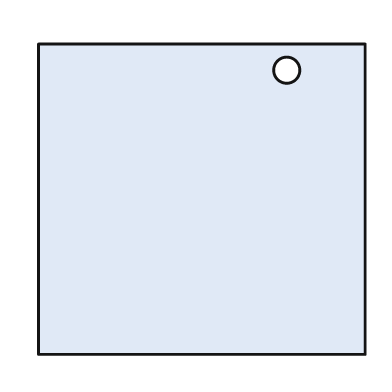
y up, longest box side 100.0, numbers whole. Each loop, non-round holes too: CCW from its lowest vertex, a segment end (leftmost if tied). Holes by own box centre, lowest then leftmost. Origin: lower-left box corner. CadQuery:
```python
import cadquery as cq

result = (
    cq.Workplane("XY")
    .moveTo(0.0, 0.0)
    .lineTo(100.0, 0.0)
    .lineTo(100.0, 95.0)
    .lineTo(0.0, 95.0)
    .close()
    .moveTo(76.0, 87.0)
    .circle(4.0)
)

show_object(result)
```